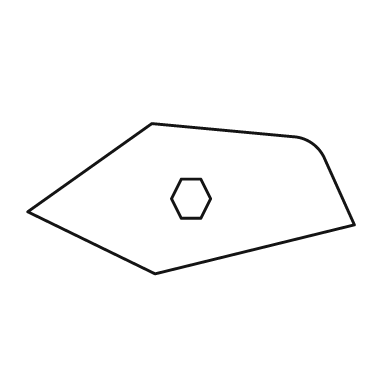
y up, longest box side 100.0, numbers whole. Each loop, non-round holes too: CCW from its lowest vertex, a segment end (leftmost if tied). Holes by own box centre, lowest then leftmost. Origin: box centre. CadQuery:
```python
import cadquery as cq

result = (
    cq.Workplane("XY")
    .moveTo(-11.0, -23.0)
    .lineTo(50.0, -8.0)
    .lineTo(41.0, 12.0)
    .threePointArc((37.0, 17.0), (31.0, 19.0))
    .lineTo(-12.0, 23.0)
    .lineTo(-50.0, -4.0)
    .close()
    .moveTo(-3.0, -6.0)
    .lineTo(3.0, -6.0)
    .lineTo(6.0, 0.0)
    .lineTo(3.0, 6.0)
    .lineTo(-3.0, 6.0)
    .lineTo(-6.0, 0.0)
    .close()
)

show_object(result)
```